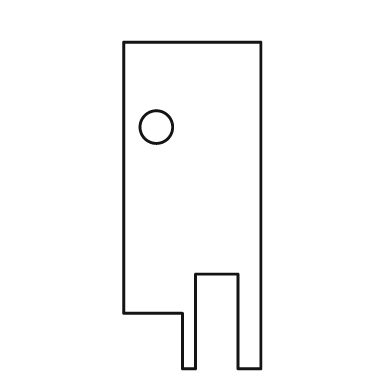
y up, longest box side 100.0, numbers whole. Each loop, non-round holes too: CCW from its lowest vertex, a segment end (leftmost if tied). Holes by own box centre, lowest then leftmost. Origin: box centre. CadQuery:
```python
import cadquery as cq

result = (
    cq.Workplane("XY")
    .moveTo(-3.0, -50.0)
    .lineTo(1.0, -50.0)
    .lineTo(1.0, -21.0)
    .lineTo(14.0, -21.0)
    .lineTo(14.0, -50.0)
    .lineTo(21.0, -50.0)
    .lineTo(21.0, 50.0)
    .lineTo(-21.0, 50.0)
    .lineTo(-21.0, -33.0)
    .lineTo(-3.0, -33.0)
    .close()
    .moveTo(-11.0, 24.0)
    .circle(5.0)
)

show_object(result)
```